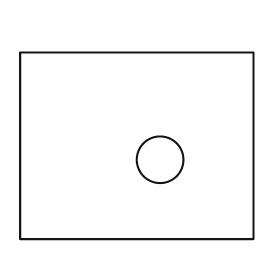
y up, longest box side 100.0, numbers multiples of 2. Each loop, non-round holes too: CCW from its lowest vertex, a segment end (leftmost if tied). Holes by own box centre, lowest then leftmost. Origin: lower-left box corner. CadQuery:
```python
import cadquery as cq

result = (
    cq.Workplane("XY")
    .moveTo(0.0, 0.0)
    .lineTo(100.0, 0.0)
    .lineTo(100.0, 80.0)
    .lineTo(0.0, 80.0)
    .close()
    .moveTo(60.0, 34.0)
    .circle(10.0)
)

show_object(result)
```